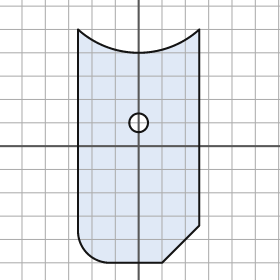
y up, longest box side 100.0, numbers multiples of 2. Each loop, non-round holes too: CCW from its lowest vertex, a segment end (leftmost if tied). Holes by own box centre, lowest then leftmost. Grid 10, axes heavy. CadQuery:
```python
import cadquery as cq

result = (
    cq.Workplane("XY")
    .moveTo(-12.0, -50.0)
    .lineTo(10.0, -50.0)
    .lineTo(26.0, -34.0)
    .lineTo(26.0, 50.0)
    .threePointArc((0.0, 40.0), (-26.0, 50.0))
    .lineTo(-26.0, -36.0)
    .threePointArc((-22.0, -46.0), (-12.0, -50.0))
    .close()
    .moveTo(0.0, 10.0)
    .circle(4.0)
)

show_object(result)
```